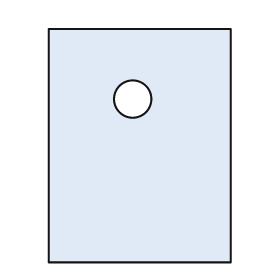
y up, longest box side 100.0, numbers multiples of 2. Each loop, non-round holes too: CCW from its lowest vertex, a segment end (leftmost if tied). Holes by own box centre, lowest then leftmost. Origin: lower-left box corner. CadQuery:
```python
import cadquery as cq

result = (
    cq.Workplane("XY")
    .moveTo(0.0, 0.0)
    .lineTo(78.0, 0.0)
    .lineTo(78.0, 100.0)
    .lineTo(0.0, 100.0)
    .close()
    .moveTo(36.0, 70.0)
    .circle(8.0)
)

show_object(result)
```